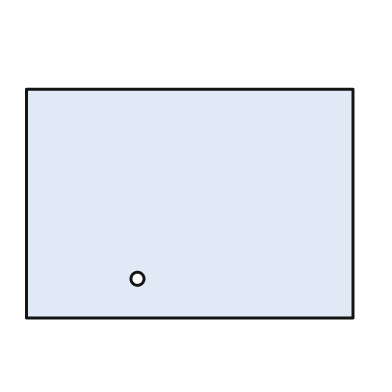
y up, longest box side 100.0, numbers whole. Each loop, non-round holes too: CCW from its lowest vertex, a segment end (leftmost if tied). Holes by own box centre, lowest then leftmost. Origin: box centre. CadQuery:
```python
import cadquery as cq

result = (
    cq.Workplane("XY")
    .moveTo(-50.0, -35.0)
    .lineTo(50.0, -35.0)
    .lineTo(50.0, 35.0)
    .lineTo(-50.0, 35.0)
    .close()
    .moveTo(-16.0, -23.0)
    .circle(2.0)
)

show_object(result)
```